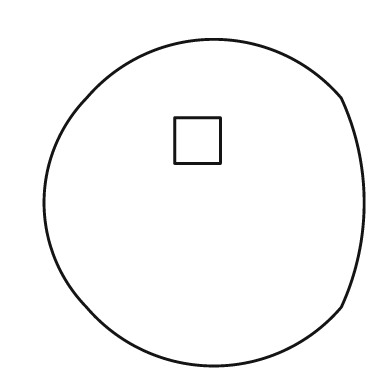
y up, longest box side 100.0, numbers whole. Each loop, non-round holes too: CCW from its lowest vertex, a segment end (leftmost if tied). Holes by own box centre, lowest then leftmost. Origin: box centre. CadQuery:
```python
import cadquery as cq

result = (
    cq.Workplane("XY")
    .moveTo(-36.0, -32.0)
    .threePointArc((3.0, -50.0), (42.0, -32.0))
    .threePointArc((49.0, 0.0), (42.0, 32.0))
    .threePointArc((3.0, 50.0), (-36.0, 32.0))
    .threePointArc((-49.0, 0.0), (-36.0, -32.0))
    .close()
    .moveTo(-9.0, 12.0)
    .lineTo(5.0, 12.0)
    .lineTo(5.0, 26.0)
    .lineTo(-9.0, 26.0)
    .close()
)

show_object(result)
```